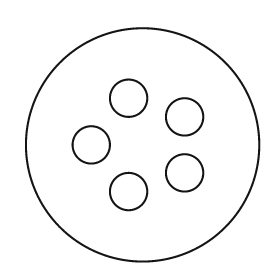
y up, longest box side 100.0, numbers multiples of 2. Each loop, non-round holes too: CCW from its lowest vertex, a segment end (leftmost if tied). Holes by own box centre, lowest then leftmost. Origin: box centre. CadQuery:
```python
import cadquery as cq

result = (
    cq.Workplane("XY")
    .moveTo(0.0, 0.0)
    .circle(50.0)
    .moveTo(-6.0, -20.0)
    .circle(8.0)
    .moveTo(18.0, -12.0)
    .circle(8.0)
    .moveTo(-22.0, 0.0)
    .circle(8.0)
    .moveTo(18.0, 12.0)
    .circle(8.0)
    .moveTo(-6.0, 20.0)
    .circle(8.0)
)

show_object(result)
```